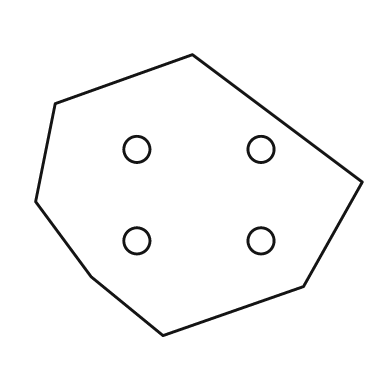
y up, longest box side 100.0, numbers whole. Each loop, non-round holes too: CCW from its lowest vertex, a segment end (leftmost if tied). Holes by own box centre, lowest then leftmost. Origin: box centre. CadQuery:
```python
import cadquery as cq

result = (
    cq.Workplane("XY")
    .moveTo(-11.0, -43.0)
    .lineTo(32.0, -28.0)
    .lineTo(50.0, 4.0)
    .lineTo(-2.0, 43.0)
    .lineTo(-44.0, 28.0)
    .lineTo(-50.0, -2.0)
    .lineTo(-33.0, -25.0)
    .close()
    .moveTo(-19.0, -14.0)
    .circle(4.0)
    .moveTo(19.0, -14.0)
    .circle(4.0)
    .moveTo(-19.0, 14.0)
    .circle(4.0)
    .moveTo(19.0, 14.0)
    .circle(4.0)
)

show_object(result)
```